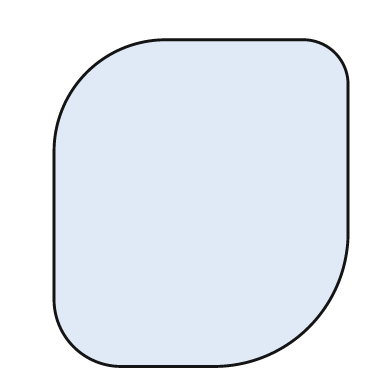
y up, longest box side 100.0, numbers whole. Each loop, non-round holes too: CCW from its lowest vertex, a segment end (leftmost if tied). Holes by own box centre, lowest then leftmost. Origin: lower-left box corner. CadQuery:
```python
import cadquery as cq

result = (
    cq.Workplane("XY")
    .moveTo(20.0, 0.0)
    .lineTo(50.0, 0.0)
    .threePointArc((78.0, 12.0), (90.0, 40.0))
    .lineTo(90.0, 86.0)
    .threePointArc((86.0, 96.0), (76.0, 100.0))
    .lineTo(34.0, 100.0)
    .threePointArc((10.0, 90.0), (0.0, 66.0))
    .lineTo(0.0, 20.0)
    .threePointArc((6.0, 6.0), (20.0, 0.0))
    .close()
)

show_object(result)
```